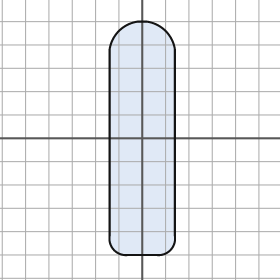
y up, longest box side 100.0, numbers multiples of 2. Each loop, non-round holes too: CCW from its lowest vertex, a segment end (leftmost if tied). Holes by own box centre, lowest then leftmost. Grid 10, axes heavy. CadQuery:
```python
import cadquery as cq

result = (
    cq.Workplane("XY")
    .moveTo(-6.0, -50.0)
    .lineTo(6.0, -50.0)
    .threePointArc((12.0, -48.0), (14.0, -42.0))
    .lineTo(14.0, 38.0)
    .threePointArc((10.0, 46.0), (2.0, 50.0))
    .lineTo(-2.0, 50.0)
    .threePointArc((-10.0, 46.0), (-14.0, 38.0))
    .lineTo(-14.0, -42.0)
    .threePointArc((-12.0, -48.0), (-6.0, -50.0))
    .close()
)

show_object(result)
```